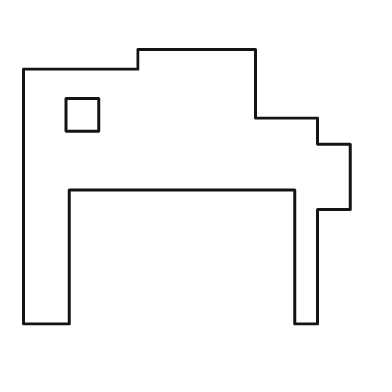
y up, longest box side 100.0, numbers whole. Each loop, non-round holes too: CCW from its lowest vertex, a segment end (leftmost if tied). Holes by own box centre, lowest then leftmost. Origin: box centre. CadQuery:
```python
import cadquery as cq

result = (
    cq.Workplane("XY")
    .moveTo(-50.0, -42.0)
    .lineTo(-36.0, -42.0)
    .lineTo(-36.0, -1.0)
    .lineTo(33.0, -1.0)
    .lineTo(33.0, -42.0)
    .lineTo(40.0, -42.0)
    .lineTo(40.0, -7.0)
    .lineTo(50.0, -7.0)
    .lineTo(50.0, 13.0)
    .lineTo(40.0, 13.0)
    .lineTo(40.0, 21.0)
    .lineTo(21.0, 21.0)
    .lineTo(21.0, 42.0)
    .lineTo(-15.0, 42.0)
    .lineTo(-15.0, 36.0)
    .lineTo(-50.0, 36.0)
    .close()
    .moveTo(-37.0, 17.0)
    .lineTo(-27.0, 17.0)
    .lineTo(-27.0, 27.0)
    .lineTo(-37.0, 27.0)
    .close()
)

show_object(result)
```